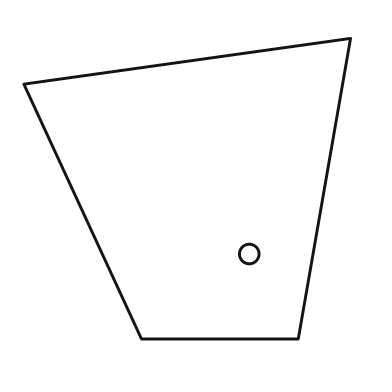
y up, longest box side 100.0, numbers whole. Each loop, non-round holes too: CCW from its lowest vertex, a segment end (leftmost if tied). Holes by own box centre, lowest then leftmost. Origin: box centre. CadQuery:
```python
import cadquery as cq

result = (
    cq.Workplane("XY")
    .moveTo(-14.0, -46.0)
    .lineTo(34.0, -46.0)
    .lineTo(50.0, 46.0)
    .lineTo(-50.0, 32.0)
    .close()
    .moveTo(19.0, -20.0)
    .circle(3.0)
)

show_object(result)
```